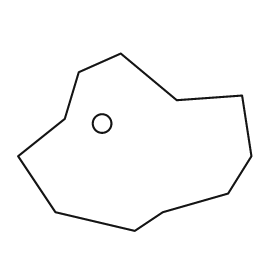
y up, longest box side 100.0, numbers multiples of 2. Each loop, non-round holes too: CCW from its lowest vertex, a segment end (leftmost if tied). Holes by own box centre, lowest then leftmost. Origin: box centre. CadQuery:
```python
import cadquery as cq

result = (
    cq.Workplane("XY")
    .moveTo(0.0, -38.0)
    .lineTo(12.0, -30.0)
    .lineTo(40.0, -22.0)
    .lineTo(50.0, -6.0)
    .lineTo(46.0, 20.0)
    .lineTo(18.0, 18.0)
    .lineTo(-6.0, 38.0)
    .lineTo(-24.0, 30.0)
    .lineTo(-30.0, 10.0)
    .lineTo(-50.0, -6.0)
    .lineTo(-34.0, -30.0)
    .close()
    .moveTo(-14.0, 8.0)
    .circle(4.0)
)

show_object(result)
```